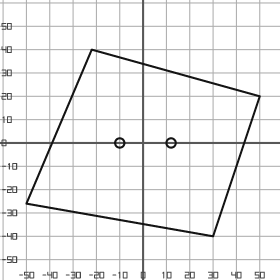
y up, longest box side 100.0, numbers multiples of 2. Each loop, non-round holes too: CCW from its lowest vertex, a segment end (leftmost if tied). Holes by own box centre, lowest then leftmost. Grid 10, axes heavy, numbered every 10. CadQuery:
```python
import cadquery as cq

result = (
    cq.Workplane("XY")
    .moveTo(30.0, -40.0)
    .lineTo(50.0, 20.0)
    .lineTo(-22.0, 40.0)
    .lineTo(-50.0, -26.0)
    .close()
    .moveTo(-10.0, 0.0)
    .circle(2.0)
    .moveTo(12.0, 0.0)
    .circle(2.0)
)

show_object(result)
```